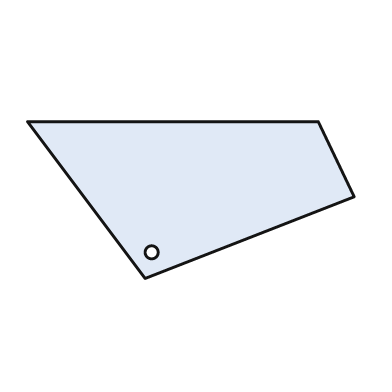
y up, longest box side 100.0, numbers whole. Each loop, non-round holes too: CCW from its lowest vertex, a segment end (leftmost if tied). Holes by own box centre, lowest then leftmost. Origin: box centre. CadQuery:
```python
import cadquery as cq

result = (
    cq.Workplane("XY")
    .moveTo(-14.0, -24.0)
    .lineTo(50.0, 1.0)
    .lineTo(39.0, 24.0)
    .lineTo(-50.0, 24.0)
    .close()
    .moveTo(-12.0, -16.0)
    .circle(2.0)
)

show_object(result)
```